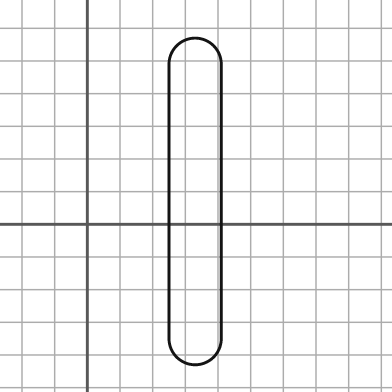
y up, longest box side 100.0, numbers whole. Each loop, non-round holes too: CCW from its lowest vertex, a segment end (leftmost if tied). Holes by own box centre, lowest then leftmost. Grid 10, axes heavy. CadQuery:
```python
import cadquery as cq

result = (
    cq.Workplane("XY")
    .moveTo(25.0, -35.0)
    .threePointArc((33.0, -43.0), (41.0, -35.0))
    .lineTo(41.0, 49.0)
    .threePointArc((33.0, 57.0), (25.0, 49.0))
    .close()
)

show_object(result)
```